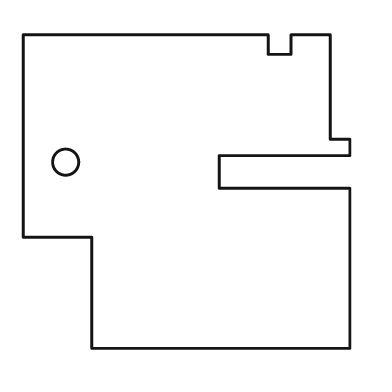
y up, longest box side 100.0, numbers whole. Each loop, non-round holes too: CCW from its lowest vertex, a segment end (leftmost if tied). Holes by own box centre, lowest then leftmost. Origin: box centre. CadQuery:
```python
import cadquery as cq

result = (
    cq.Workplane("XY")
    .moveTo(-29.0, -48.0)
    .lineTo(50.0, -48.0)
    .lineTo(50.0, 1.0)
    .lineTo(10.0, 1.0)
    .lineTo(10.0, 11.0)
    .lineTo(50.0, 11.0)
    .lineTo(50.0, 16.0)
    .lineTo(44.0, 16.0)
    .lineTo(44.0, 48.0)
    .lineTo(32.0, 48.0)
    .lineTo(32.0, 42.0)
    .lineTo(25.0, 42.0)
    .lineTo(25.0, 48.0)
    .lineTo(-50.0, 48.0)
    .lineTo(-50.0, -14.0)
    .lineTo(-29.0, -14.0)
    .close()
    .moveTo(-37.0, 9.0)
    .circle(4.0)
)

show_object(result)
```